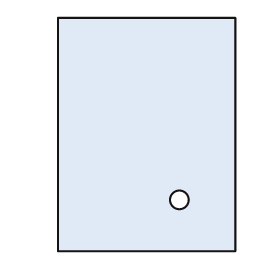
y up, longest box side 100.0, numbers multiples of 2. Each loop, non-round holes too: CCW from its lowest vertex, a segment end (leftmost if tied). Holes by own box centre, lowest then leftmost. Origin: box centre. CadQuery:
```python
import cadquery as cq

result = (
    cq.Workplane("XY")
    .moveTo(-38.0, -50.0)
    .lineTo(38.0, -50.0)
    .lineTo(38.0, 50.0)
    .lineTo(-38.0, 50.0)
    .close()
    .moveTo(14.0, -28.0)
    .circle(4.0)
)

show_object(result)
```